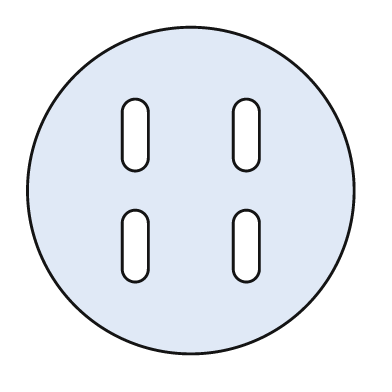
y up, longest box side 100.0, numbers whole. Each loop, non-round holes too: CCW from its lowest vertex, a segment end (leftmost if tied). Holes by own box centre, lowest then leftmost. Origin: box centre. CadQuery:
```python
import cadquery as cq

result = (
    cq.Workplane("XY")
    .moveTo(0.0, 0.0)
    .circle(50.0)
    .moveTo(-21.0, -24.0)
    .threePointArc((-17.0, -28.0), (-13.0, -24.0))
    .lineTo(-13.0, -10.0)
    .threePointArc((-17.0, -6.0), (-21.0, -10.0))
    .close()
    .moveTo(13.0, -24.0)
    .threePointArc((17.0, -28.0), (21.0, -24.0))
    .lineTo(21.0, -10.0)
    .threePointArc((17.0, -6.0), (13.0, -10.0))
    .close()
    .moveTo(-21.0, 10.0)
    .threePointArc((-17.0, 6.0), (-13.0, 10.0))
    .lineTo(-13.0, 24.0)
    .threePointArc((-17.0, 28.0), (-21.0, 24.0))
    .close()
    .moveTo(13.0, 10.0)
    .threePointArc((17.0, 6.0), (21.0, 10.0))
    .lineTo(21.0, 24.0)
    .threePointArc((17.0, 28.0), (13.0, 24.0))
    .close()
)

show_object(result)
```